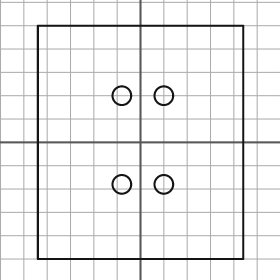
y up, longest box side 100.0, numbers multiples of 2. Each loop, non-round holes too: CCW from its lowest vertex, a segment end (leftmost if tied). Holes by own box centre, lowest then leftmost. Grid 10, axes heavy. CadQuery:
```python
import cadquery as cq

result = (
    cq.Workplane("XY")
    .moveTo(-44.0, -50.0)
    .lineTo(44.0, -50.0)
    .lineTo(44.0, 50.0)
    .lineTo(-44.0, 50.0)
    .close()
    .moveTo(-8.0, -18.0)
    .circle(4.0)
    .moveTo(10.0, -18.0)
    .circle(4.0)
    .moveTo(-8.0, 20.0)
    .circle(4.0)
    .moveTo(10.0, 20.0)
    .circle(4.0)
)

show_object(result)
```